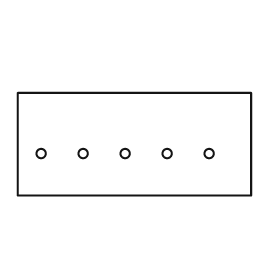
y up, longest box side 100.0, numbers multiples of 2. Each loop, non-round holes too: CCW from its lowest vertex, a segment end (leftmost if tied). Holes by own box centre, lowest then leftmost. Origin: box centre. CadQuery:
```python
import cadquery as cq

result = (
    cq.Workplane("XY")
    .moveTo(-50.0, -22.0)
    .lineTo(50.0, -22.0)
    .lineTo(50.0, 22.0)
    .lineTo(-50.0, 22.0)
    .close()
    .moveTo(-40.0, -4.0)
    .circle(2.0)
    .moveTo(-22.0, -4.0)
    .circle(2.0)
    .moveTo(-4.0, -4.0)
    .circle(2.0)
    .moveTo(14.0, -4.0)
    .circle(2.0)
    .moveTo(32.0, -4.0)
    .circle(2.0)
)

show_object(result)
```